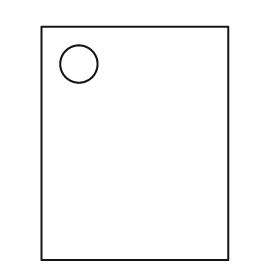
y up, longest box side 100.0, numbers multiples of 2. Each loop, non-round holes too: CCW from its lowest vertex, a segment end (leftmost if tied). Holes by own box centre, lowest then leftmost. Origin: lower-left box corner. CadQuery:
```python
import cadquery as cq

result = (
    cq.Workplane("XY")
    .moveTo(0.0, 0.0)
    .lineTo(80.0, 0.0)
    .lineTo(80.0, 100.0)
    .lineTo(0.0, 100.0)
    .close()
    .moveTo(16.0, 84.0)
    .circle(8.0)
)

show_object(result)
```